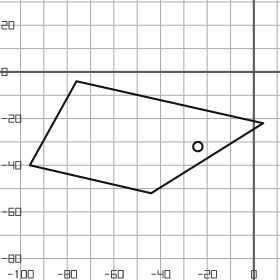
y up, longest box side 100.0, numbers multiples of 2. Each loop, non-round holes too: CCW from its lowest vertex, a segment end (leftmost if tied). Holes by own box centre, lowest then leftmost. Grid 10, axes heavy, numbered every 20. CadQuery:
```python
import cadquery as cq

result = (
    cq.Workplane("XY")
    .moveTo(-44.0, -52.0)
    .lineTo(4.0, -22.0)
    .lineTo(-76.0, -4.0)
    .lineTo(-96.0, -40.0)
    .close()
    .moveTo(-24.0, -32.0)
    .circle(2.0)
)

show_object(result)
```